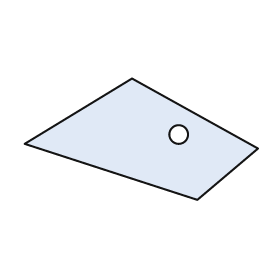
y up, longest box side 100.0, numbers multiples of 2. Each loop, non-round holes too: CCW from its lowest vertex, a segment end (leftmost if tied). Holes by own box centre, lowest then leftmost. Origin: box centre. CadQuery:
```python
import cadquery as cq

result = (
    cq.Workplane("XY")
    .moveTo(24.0, -26.0)
    .lineTo(50.0, -4.0)
    .lineTo(-4.0, 26.0)
    .lineTo(-50.0, -2.0)
    .close()
    .moveTo(16.0, 2.0)
    .circle(4.0)
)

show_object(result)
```